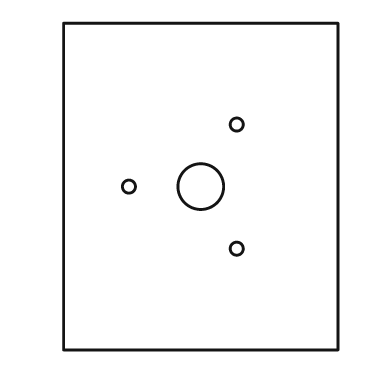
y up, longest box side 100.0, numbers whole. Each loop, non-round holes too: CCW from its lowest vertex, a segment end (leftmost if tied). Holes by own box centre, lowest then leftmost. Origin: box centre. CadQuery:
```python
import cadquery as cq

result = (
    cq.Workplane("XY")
    .moveTo(-42.0, -50.0)
    .lineTo(42.0, -50.0)
    .lineTo(42.0, 50.0)
    .lineTo(-42.0, 50.0)
    .close()
    .moveTo(11.0, -19.0)
    .circle(2.0)
    .moveTo(-22.0, 0.0)
    .circle(2.0)
    .moveTo(0.0, 0.0)
    .circle(7.0)
    .moveTo(11.0, 19.0)
    .circle(2.0)
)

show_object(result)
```